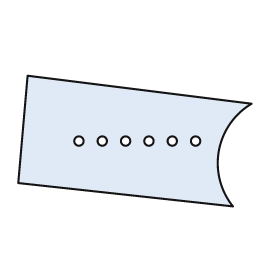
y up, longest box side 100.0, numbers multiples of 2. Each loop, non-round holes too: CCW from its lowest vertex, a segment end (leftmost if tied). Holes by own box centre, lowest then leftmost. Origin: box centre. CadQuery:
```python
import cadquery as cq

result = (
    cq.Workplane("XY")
    .moveTo(42.0, -28.0)
    .threePointArc((36.0, -4.0), (50.0, 16.0))
    .lineTo(-46.0, 28.0)
    .lineTo(-50.0, -18.0)
    .close()
    .moveTo(-24.0, 0.0)
    .circle(2.0)
    .moveTo(-14.0, 0.0)
    .circle(2.0)
    .moveTo(-4.0, 0.0)
    .circle(2.0)
    .moveTo(6.0, 0.0)
    .circle(2.0)
    .moveTo(16.0, 0.0)
    .circle(2.0)
    .moveTo(26.0, 0.0)
    .circle(2.0)
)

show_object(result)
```